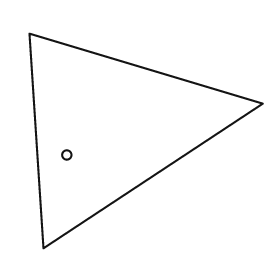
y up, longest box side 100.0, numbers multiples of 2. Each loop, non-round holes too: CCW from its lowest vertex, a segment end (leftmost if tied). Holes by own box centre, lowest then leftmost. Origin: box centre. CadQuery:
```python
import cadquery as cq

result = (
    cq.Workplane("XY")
    .moveTo(-44.0, -46.0)
    .lineTo(50.0, 16.0)
    .lineTo(-50.0, 46.0)
    .close()
    .moveTo(-34.0, -6.0)
    .circle(2.0)
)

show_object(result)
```